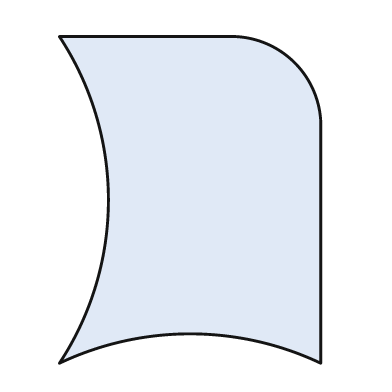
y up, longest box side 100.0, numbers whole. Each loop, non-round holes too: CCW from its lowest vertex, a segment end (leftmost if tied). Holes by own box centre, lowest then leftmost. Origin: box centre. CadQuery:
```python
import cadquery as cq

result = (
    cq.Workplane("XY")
    .moveTo(-40.0, -50.0)
    .threePointArc((0.0, -41.0), (40.0, -50.0))
    .lineTo(40.0, 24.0)
    .threePointArc((32.0, 42.0), (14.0, 50.0))
    .lineTo(-40.0, 50.0)
    .threePointArc((-25.0, 0.0), (-40.0, -50.0))
    .close()
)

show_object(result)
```